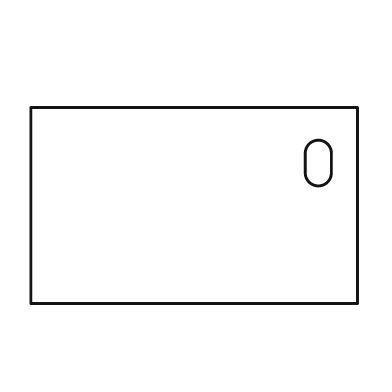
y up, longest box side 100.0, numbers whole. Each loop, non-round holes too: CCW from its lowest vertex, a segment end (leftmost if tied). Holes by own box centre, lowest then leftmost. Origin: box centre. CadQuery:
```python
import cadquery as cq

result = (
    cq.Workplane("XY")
    .moveTo(-50.0, -30.0)
    .lineTo(50.0, -30.0)
    .lineTo(50.0, 30.0)
    .lineTo(-50.0, 30.0)
    .close()
    .moveTo(34.0, 10.0)
    .threePointArc((38.0, 6.0), (42.0, 10.0))
    .lineTo(42.0, 16.0)
    .threePointArc((38.0, 20.0), (34.0, 16.0))
    .close()
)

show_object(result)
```